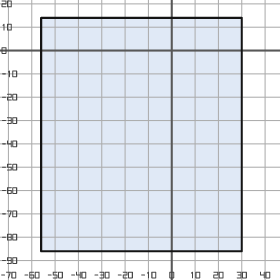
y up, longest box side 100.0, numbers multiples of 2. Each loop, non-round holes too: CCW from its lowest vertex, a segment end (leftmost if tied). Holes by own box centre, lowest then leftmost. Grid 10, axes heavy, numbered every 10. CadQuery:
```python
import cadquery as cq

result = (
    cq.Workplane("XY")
    .moveTo(-56.0, -86.0)
    .lineTo(30.0, -86.0)
    .lineTo(30.0, 14.0)
    .lineTo(-56.0, 14.0)
    .close()
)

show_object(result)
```